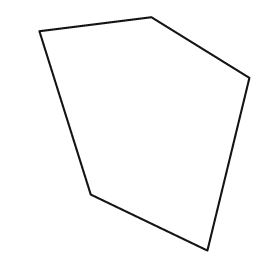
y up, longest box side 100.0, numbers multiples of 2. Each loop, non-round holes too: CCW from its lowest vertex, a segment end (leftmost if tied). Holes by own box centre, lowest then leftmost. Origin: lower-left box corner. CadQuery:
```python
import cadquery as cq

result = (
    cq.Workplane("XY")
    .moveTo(72.0, 0.0)
    .lineTo(90.0, 74.0)
    .lineTo(48.0, 100.0)
    .lineTo(0.0, 94.0)
    .lineTo(22.0, 24.0)
    .close()
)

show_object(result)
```